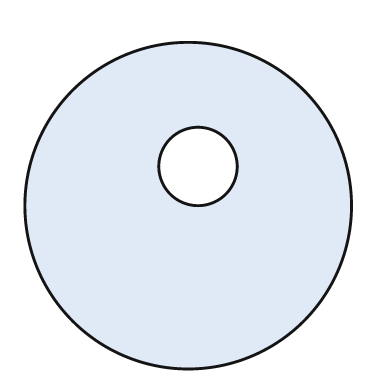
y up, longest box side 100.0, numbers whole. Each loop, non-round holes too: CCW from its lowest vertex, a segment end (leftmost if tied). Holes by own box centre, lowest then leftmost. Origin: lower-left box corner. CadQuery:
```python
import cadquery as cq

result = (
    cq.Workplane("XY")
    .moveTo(50.0, 50.0)
    .circle(50.0)
    .moveTo(53.0, 62.0)
    .circle(12.0)
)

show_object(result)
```